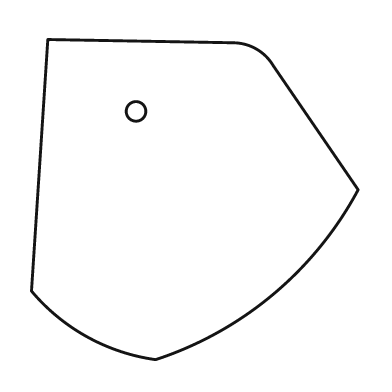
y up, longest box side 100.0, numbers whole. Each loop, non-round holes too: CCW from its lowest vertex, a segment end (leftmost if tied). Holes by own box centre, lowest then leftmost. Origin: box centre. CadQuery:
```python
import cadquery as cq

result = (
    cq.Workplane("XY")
    .moveTo(-12.0, -49.0)
    .threePointArc((24.0, -29.0), (50.0, 3.0))
    .lineTo(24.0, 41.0)
    .threePointArc((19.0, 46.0), (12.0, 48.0))
    .lineTo(-45.0, 49.0)
    .lineTo(-50.0, -28.0)
    .threePointArc((-33.0, -42.0), (-12.0, -49.0))
    .close()
    .moveTo(-18.0, 27.0)
    .circle(3.0)
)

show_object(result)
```